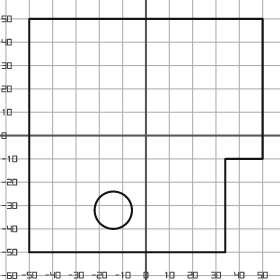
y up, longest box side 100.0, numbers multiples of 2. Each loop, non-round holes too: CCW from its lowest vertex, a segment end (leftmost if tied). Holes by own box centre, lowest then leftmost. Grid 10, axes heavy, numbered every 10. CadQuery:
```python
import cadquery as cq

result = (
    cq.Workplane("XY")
    .moveTo(-50.0, -50.0)
    .lineTo(34.0, -50.0)
    .lineTo(34.0, -10.0)
    .lineTo(50.0, -10.0)
    .lineTo(50.0, 50.0)
    .lineTo(-50.0, 50.0)
    .close()
    .moveTo(-14.0, -32.0)
    .circle(8.0)
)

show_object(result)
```